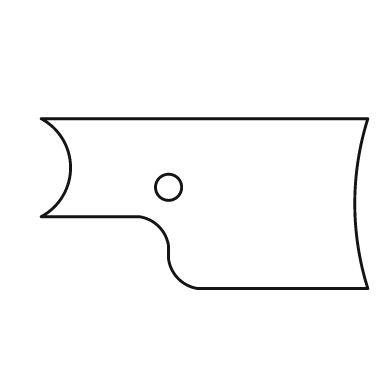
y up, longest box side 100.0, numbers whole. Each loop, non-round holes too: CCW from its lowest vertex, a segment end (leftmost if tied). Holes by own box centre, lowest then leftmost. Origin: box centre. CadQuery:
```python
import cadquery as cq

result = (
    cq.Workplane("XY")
    .moveTo(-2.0, -26.0)
    .lineTo(50.0, -26.0)
    .threePointArc((46.0, 0.0), (50.0, 26.0))
    .lineTo(-50.0, 26.0)
    .threePointArc((-41.0, 11.0), (-50.0, -4.0))
    .lineTo(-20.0, -4.0)
    .threePointArc((-14.0, -7.0), (-11.0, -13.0))
    .lineTo(-11.0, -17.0)
    .threePointArc((-8.0, -23.0), (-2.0, -26.0))
    .close()
    .moveTo(-11.0, 5.0)
    .circle(4.0)
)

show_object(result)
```